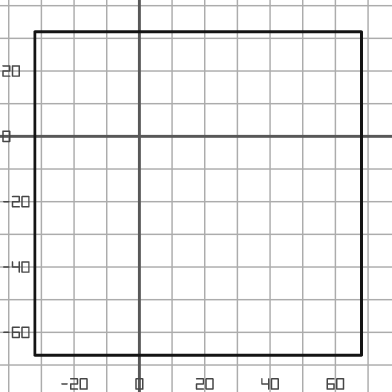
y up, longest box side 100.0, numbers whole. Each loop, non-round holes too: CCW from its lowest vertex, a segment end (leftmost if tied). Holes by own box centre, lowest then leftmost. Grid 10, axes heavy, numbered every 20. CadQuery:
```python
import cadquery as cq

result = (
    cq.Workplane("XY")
    .moveTo(-32.0, -67.0)
    .lineTo(68.0, -67.0)
    .lineTo(68.0, 32.0)
    .lineTo(-32.0, 32.0)
    .close()
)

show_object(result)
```